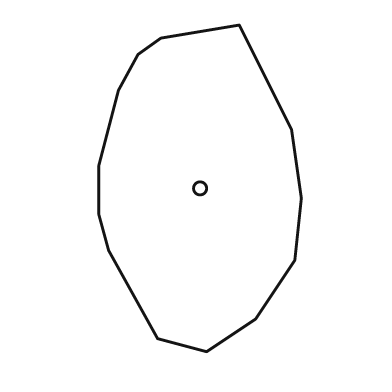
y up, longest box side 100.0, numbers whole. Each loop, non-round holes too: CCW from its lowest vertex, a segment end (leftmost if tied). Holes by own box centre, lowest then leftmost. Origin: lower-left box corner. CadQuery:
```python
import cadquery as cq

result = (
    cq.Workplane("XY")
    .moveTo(33.0, 0.0)
    .lineTo(48.0, 10.0)
    .lineTo(60.0, 28.0)
    .lineTo(62.0, 47.0)
    .lineTo(59.0, 68.0)
    .lineTo(43.0, 100.0)
    .lineTo(19.0, 96.0)
    .lineTo(12.0, 91.0)
    .lineTo(6.0, 80.0)
    .lineTo(0.0, 57.0)
    .lineTo(0.0, 42.0)
    .lineTo(3.0, 31.0)
    .lineTo(18.0, 4.0)
    .close()
    .moveTo(31.0, 50.0)
    .circle(2.0)
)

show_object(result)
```